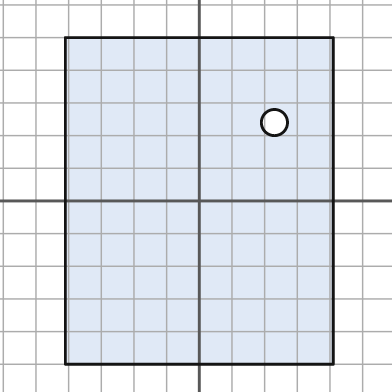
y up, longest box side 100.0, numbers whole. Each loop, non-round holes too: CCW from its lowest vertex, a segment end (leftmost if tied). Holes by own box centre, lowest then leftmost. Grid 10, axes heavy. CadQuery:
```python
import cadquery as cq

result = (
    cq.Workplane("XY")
    .moveTo(-41.0, -50.0)
    .lineTo(41.0, -50.0)
    .lineTo(41.0, 50.0)
    .lineTo(-41.0, 50.0)
    .close()
    .moveTo(23.0, 24.0)
    .circle(4.0)
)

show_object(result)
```